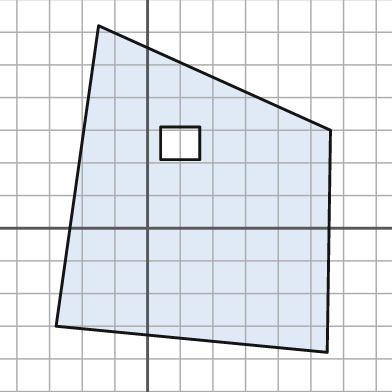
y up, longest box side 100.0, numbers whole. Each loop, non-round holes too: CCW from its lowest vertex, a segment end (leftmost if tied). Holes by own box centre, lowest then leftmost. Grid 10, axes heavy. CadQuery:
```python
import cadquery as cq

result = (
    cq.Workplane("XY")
    .moveTo(55.0, -38.0)
    .lineTo(56.0, 30.0)
    .lineTo(-15.0, 62.0)
    .lineTo(-28.0, -30.0)
    .close()
    .moveTo(4.0, 21.0)
    .lineTo(16.0, 21.0)
    .lineTo(16.0, 31.0)
    .lineTo(4.0, 31.0)
    .close()
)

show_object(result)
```